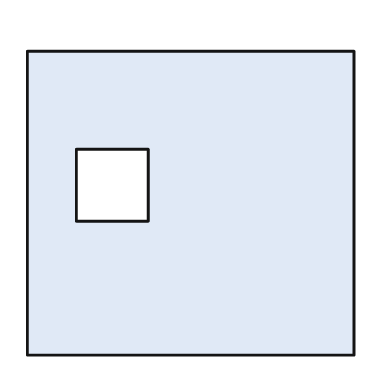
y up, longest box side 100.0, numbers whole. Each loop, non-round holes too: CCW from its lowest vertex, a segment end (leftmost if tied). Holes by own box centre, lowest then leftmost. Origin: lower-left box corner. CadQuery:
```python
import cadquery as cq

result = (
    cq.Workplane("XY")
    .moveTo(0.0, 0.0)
    .lineTo(100.0, 0.0)
    .lineTo(100.0, 93.0)
    .lineTo(0.0, 93.0)
    .close()
    .moveTo(15.0, 41.0)
    .lineTo(37.0, 41.0)
    .lineTo(37.0, 63.0)
    .lineTo(15.0, 63.0)
    .close()
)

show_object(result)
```